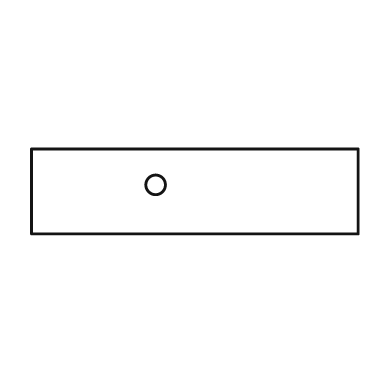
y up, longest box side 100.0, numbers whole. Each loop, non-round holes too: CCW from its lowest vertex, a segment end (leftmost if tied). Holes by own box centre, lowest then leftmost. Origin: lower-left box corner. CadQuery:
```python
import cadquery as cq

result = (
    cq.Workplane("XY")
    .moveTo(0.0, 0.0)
    .lineTo(100.0, 0.0)
    .lineTo(100.0, 26.0)
    .lineTo(0.0, 26.0)
    .close()
    .moveTo(38.0, 15.0)
    .circle(3.0)
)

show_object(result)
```